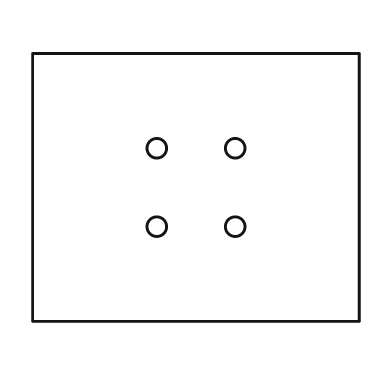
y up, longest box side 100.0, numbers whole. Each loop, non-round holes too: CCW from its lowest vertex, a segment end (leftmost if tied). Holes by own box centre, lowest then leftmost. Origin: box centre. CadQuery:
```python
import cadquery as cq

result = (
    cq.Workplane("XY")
    .moveTo(-50.0, -41.0)
    .lineTo(50.0, -41.0)
    .lineTo(50.0, 41.0)
    .lineTo(-50.0, 41.0)
    .close()
    .moveTo(-12.0, -12.0)
    .circle(3.0)
    .moveTo(12.0, -12.0)
    .circle(3.0)
    .moveTo(-12.0, 12.0)
    .circle(3.0)
    .moveTo(12.0, 12.0)
    .circle(3.0)
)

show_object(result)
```